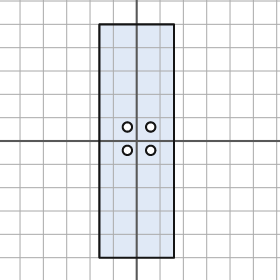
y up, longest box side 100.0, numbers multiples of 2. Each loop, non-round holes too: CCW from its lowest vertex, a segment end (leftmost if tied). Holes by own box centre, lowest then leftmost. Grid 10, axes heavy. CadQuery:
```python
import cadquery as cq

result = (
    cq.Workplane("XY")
    .moveTo(-16.0, -50.0)
    .lineTo(16.0, -50.0)
    .lineTo(16.0, 50.0)
    .lineTo(-16.0, 50.0)
    .close()
    .moveTo(-4.0, -4.0)
    .circle(2.0)
    .moveTo(6.0, -4.0)
    .circle(2.0)
    .moveTo(-4.0, 6.0)
    .circle(2.0)
    .moveTo(6.0, 6.0)
    .circle(2.0)
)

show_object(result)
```